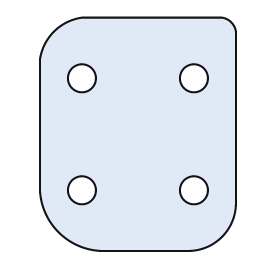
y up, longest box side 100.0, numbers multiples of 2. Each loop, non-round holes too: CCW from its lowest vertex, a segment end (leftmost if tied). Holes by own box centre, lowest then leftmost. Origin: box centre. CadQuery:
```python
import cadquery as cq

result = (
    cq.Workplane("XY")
    .moveTo(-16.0, -50.0)
    .lineTo(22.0, -50.0)
    .threePointArc((36.0, -44.0), (42.0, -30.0))
    .lineTo(42.0, 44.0)
    .threePointArc((40.0, 48.0), (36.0, 50.0))
    .lineTo(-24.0, 50.0)
    .threePointArc((-36.0, 44.0), (-42.0, 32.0))
    .lineTo(-42.0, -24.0)
    .threePointArc((-34.0, -42.0), (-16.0, -50.0))
    .close()
    .moveTo(-24.0, -24.0)
    .circle(6.0)
    .moveTo(24.0, -24.0)
    .circle(6.0)
    .moveTo(-24.0, 24.0)
    .circle(6.0)
    .moveTo(24.0, 24.0)
    .circle(6.0)
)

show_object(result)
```